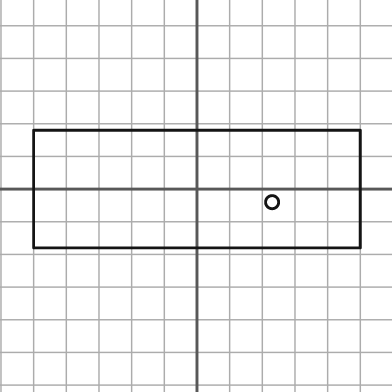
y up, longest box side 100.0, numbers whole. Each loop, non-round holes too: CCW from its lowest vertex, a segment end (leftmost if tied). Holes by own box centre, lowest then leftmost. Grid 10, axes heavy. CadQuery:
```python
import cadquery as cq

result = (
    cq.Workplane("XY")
    .moveTo(-50.0, -18.0)
    .lineTo(50.0, -18.0)
    .lineTo(50.0, 18.0)
    .lineTo(-50.0, 18.0)
    .close()
    .moveTo(23.0, -4.0)
    .circle(2.0)
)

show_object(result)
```